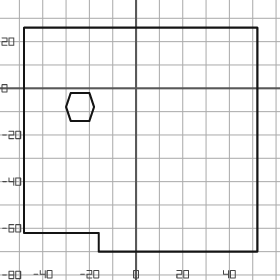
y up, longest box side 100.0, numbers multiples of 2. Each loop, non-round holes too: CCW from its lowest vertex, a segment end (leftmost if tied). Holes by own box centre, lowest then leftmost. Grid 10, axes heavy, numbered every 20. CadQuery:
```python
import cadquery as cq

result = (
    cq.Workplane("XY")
    .moveTo(-16.0, -70.0)
    .lineTo(52.0, -70.0)
    .lineTo(52.0, 26.0)
    .lineTo(-48.0, 26.0)
    .lineTo(-48.0, -62.0)
    .lineTo(-16.0, -62.0)
    .close()
    .moveTo(-28.0, -14.0)
    .lineTo(-20.0, -14.0)
    .lineTo(-18.0, -8.0)
    .lineTo(-20.0, -2.0)
    .lineTo(-28.0, -2.0)
    .lineTo(-30.0, -8.0)
    .close()
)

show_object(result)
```